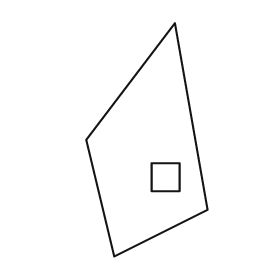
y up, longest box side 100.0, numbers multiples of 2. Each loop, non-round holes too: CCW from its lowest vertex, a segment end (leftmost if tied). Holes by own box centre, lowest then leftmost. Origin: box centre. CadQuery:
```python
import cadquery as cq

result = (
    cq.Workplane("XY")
    .moveTo(-14.0, -50.0)
    .lineTo(26.0, -30.0)
    .lineTo(12.0, 50.0)
    .lineTo(-26.0, 0.0)
    .close()
    .moveTo(2.0, -22.0)
    .lineTo(14.0, -22.0)
    .lineTo(14.0, -10.0)
    .lineTo(2.0, -10.0)
    .close()
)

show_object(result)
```